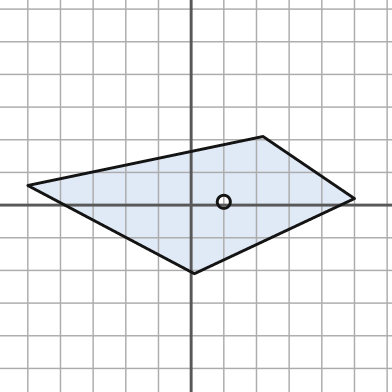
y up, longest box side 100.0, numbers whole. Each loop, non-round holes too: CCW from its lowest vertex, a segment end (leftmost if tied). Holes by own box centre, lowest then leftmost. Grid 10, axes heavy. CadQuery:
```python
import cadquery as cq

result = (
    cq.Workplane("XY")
    .moveTo(1.0, -21.0)
    .lineTo(50.0, 2.0)
    .lineTo(22.0, 21.0)
    .lineTo(-50.0, 6.0)
    .close()
    .moveTo(10.0, 1.0)
    .circle(2.0)
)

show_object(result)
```